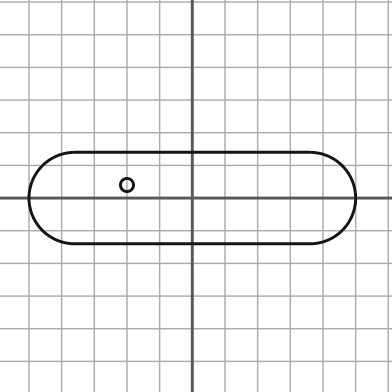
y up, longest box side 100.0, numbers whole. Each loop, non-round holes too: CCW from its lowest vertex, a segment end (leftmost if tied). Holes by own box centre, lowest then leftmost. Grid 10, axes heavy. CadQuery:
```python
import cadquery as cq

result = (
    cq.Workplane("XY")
    .moveTo(-36.0, -14.0)
    .lineTo(36.0, -14.0)
    .threePointArc((50.0, 0.0), (36.0, 14.0))
    .lineTo(-36.0, 14.0)
    .threePointArc((-50.0, 0.0), (-36.0, -14.0))
    .close()
    .moveTo(-20.0, 4.0)
    .circle(2.0)
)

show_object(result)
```